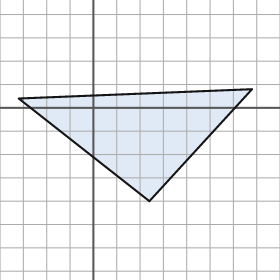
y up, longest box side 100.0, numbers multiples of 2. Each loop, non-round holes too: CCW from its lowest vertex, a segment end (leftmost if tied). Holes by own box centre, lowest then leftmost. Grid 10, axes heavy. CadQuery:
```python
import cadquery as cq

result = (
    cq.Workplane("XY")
    .moveTo(24.0, -40.0)
    .lineTo(68.0, 8.0)
    .lineTo(-32.0, 4.0)
    .close()
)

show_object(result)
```